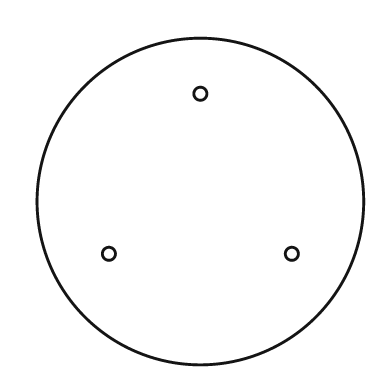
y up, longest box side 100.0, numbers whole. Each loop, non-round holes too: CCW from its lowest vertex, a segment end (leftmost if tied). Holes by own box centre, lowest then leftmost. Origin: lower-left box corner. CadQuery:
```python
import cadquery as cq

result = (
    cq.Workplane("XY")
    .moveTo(50.0, 50.0)
    .circle(50.0)
    .moveTo(22.0, 34.0)
    .circle(2.0)
    .moveTo(78.0, 34.0)
    .circle(2.0)
    .moveTo(50.0, 83.0)
    .circle(2.0)
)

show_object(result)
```